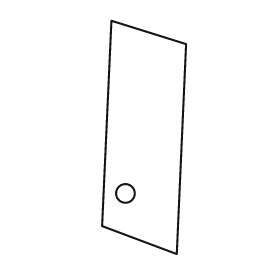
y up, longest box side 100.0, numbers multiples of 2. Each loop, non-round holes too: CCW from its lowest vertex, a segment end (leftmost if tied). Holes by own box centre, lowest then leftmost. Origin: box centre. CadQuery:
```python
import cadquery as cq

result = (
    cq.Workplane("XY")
    .moveTo(14.0, -50.0)
    .lineTo(18.0, 40.0)
    .lineTo(-14.0, 50.0)
    .lineTo(-18.0, -38.0)
    .close()
    .moveTo(-8.0, -24.0)
    .circle(4.0)
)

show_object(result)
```